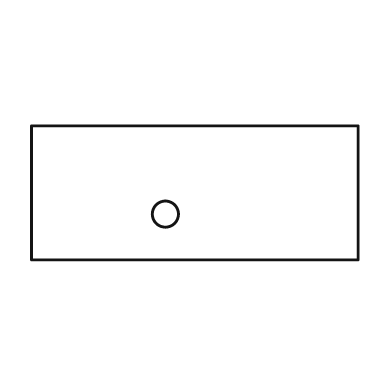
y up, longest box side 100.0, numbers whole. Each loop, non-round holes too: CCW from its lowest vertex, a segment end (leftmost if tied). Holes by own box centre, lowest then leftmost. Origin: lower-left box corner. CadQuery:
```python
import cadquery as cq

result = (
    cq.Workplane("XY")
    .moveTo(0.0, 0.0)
    .lineTo(100.0, 0.0)
    .lineTo(100.0, 41.0)
    .lineTo(0.0, 41.0)
    .close()
    .moveTo(41.0, 14.0)
    .circle(4.0)
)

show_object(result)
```